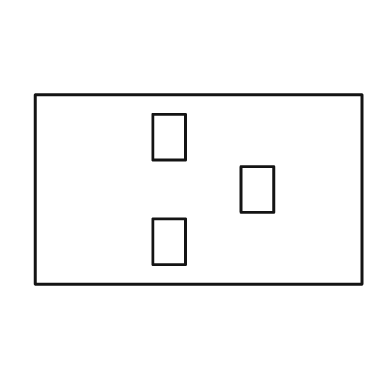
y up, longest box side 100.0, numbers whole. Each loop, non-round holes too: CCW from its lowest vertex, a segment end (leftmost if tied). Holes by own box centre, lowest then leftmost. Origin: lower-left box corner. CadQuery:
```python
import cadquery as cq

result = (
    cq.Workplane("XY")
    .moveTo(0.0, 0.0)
    .lineTo(100.0, 0.0)
    .lineTo(100.0, 58.0)
    .lineTo(0.0, 58.0)
    .close()
    .moveTo(36.0, 6.0)
    .lineTo(46.0, 6.0)
    .lineTo(46.0, 20.0)
    .lineTo(36.0, 20.0)
    .close()
    .moveTo(63.0, 22.0)
    .lineTo(73.0, 22.0)
    .lineTo(73.0, 36.0)
    .lineTo(63.0, 36.0)
    .close()
    .moveTo(36.0, 38.0)
    .lineTo(46.0, 38.0)
    .lineTo(46.0, 52.0)
    .lineTo(36.0, 52.0)
    .close()
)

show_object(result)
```